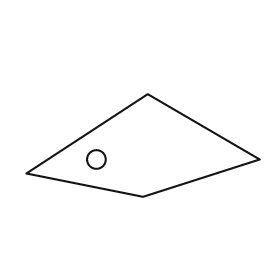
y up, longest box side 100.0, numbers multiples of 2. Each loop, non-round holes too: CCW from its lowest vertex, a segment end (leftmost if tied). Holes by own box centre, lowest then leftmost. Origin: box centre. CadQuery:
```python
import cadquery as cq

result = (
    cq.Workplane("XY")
    .moveTo(0.0, -22.0)
    .lineTo(50.0, -6.0)
    .lineTo(2.0, 22.0)
    .lineTo(-50.0, -12.0)
    .close()
    .moveTo(-20.0, -6.0)
    .circle(4.0)
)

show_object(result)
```